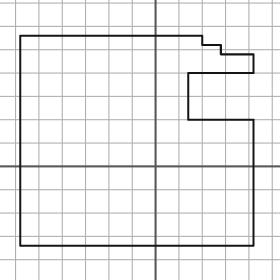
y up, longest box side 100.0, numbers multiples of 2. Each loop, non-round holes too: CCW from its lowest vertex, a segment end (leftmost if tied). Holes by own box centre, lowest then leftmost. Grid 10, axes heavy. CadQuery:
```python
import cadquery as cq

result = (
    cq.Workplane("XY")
    .moveTo(-58.0, -34.0)
    .lineTo(42.0, -34.0)
    .lineTo(42.0, 20.0)
    .lineTo(14.0, 20.0)
    .lineTo(14.0, 40.0)
    .lineTo(42.0, 40.0)
    .lineTo(42.0, 48.0)
    .lineTo(28.0, 48.0)
    .lineTo(28.0, 52.0)
    .lineTo(20.0, 52.0)
    .lineTo(20.0, 56.0)
    .lineTo(-58.0, 56.0)
    .close()
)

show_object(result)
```